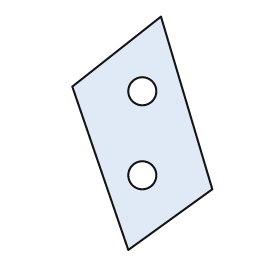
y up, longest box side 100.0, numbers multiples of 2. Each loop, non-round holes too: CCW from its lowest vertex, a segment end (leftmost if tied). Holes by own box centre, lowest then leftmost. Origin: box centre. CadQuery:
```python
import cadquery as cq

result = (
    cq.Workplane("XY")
    .moveTo(-6.0, -50.0)
    .lineTo(30.0, -24.0)
    .lineTo(8.0, 50.0)
    .lineTo(-30.0, 20.0)
    .close()
    .moveTo(0.0, -18.0)
    .circle(6.0)
    .moveTo(0.0, 18.0)
    .circle(6.0)
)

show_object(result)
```